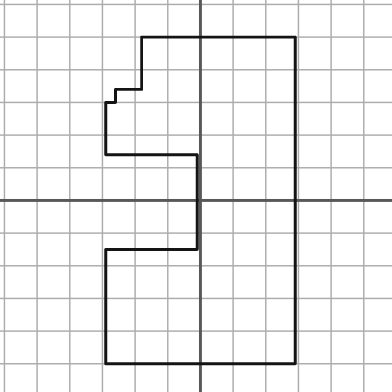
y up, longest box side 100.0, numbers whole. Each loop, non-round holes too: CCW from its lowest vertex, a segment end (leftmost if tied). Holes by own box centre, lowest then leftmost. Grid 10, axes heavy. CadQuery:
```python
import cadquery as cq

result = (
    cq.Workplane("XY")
    .moveTo(-29.0, -50.0)
    .lineTo(29.0, -50.0)
    .lineTo(29.0, 50.0)
    .lineTo(-18.0, 50.0)
    .lineTo(-18.0, 34.0)
    .lineTo(-26.0, 34.0)
    .lineTo(-26.0, 30.0)
    .lineTo(-29.0, 30.0)
    .lineTo(-29.0, 14.0)
    .lineTo(-1.0, 14.0)
    .lineTo(-1.0, -15.0)
    .lineTo(-29.0, -15.0)
    .close()
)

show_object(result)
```